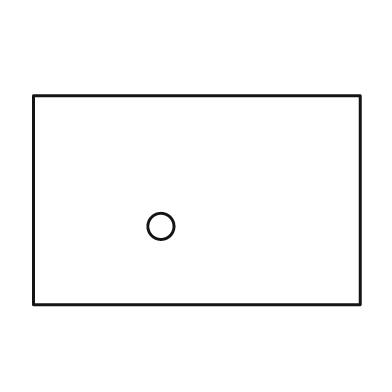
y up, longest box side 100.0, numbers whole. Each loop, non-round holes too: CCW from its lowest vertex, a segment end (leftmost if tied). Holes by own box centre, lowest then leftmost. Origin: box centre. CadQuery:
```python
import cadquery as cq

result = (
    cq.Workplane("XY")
    .moveTo(-50.0, -32.0)
    .lineTo(50.0, -32.0)
    .lineTo(50.0, 32.0)
    .lineTo(-50.0, 32.0)
    .close()
    .moveTo(-11.0, -8.0)
    .circle(4.0)
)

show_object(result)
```